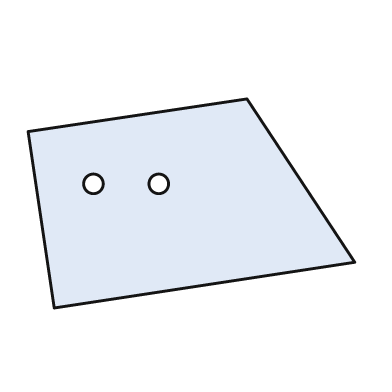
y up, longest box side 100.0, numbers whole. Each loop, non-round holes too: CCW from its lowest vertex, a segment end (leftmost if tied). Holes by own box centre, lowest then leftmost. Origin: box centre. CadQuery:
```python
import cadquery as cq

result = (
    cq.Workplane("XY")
    .moveTo(-42.0, -32.0)
    .lineTo(50.0, -18.0)
    .lineTo(17.0, 32.0)
    .lineTo(-50.0, 22.0)
    .close()
    .moveTo(-30.0, 6.0)
    .circle(3.0)
    .moveTo(-10.0, 6.0)
    .circle(3.0)
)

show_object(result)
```